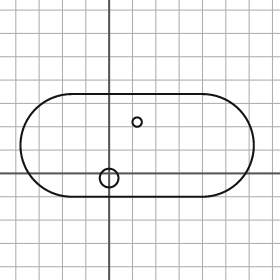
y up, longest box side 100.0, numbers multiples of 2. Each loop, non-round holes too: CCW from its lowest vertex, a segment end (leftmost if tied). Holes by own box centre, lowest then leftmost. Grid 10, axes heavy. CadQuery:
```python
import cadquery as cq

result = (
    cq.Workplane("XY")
    .moveTo(-16.0, -10.0)
    .lineTo(40.0, -10.0)
    .threePointArc((62.0, 12.0), (40.0, 34.0))
    .lineTo(-16.0, 34.0)
    .threePointArc((-38.0, 12.0), (-16.0, -10.0))
    .close()
    .moveTo(0.0, -2.0)
    .circle(4.0)
    .moveTo(12.0, 22.0)
    .circle(2.0)
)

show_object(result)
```